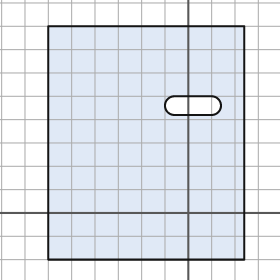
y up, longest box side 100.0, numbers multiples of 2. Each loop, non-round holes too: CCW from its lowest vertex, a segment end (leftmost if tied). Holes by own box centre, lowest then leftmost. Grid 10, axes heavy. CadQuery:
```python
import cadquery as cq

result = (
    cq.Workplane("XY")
    .moveTo(-60.0, -20.0)
    .lineTo(24.0, -20.0)
    .lineTo(24.0, 80.0)
    .lineTo(-60.0, 80.0)
    .close()
    .moveTo(-6.0, 42.0)
    .lineTo(10.0, 42.0)
    .threePointArc((14.0, 46.0), (10.0, 50.0))
    .lineTo(-6.0, 50.0)
    .threePointArc((-10.0, 46.0), (-6.0, 42.0))
    .close()
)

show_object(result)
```